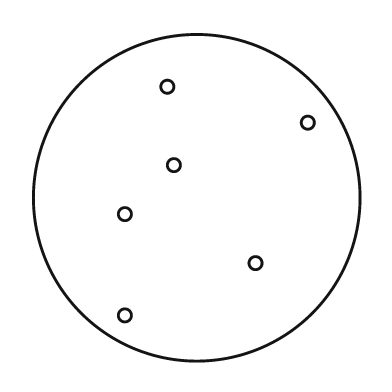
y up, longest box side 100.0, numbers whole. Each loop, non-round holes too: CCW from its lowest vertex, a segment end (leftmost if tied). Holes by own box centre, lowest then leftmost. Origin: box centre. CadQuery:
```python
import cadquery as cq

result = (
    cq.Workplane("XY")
    .moveTo(0.0, 0.0)
    .circle(50.0)
    .moveTo(-22.0, -36.0)
    .circle(2.0)
    .moveTo(18.0, -20.0)
    .circle(2.0)
    .moveTo(-22.0, -5.0)
    .circle(2.0)
    .moveTo(-7.0, 10.0)
    .circle(2.0)
    .moveTo(34.0, 23.0)
    .circle(2.0)
    .moveTo(-9.0, 34.0)
    .circle(2.0)
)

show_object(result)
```